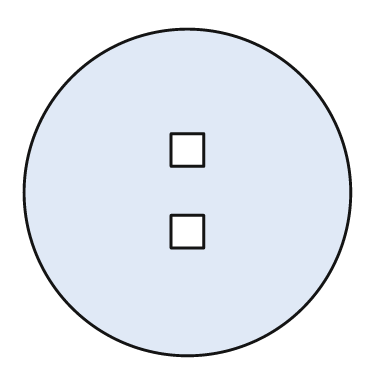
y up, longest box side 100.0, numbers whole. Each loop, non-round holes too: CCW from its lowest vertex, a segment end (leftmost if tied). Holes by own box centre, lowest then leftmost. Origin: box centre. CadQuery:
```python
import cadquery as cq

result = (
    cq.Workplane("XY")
    .moveTo(0.0, 0.0)
    .circle(50.0)
    .moveTo(-5.0, -17.0)
    .lineTo(5.0, -17.0)
    .lineTo(5.0, -7.0)
    .lineTo(-5.0, -7.0)
    .close()
    .moveTo(-5.0, 8.0)
    .lineTo(5.0, 8.0)
    .lineTo(5.0, 18.0)
    .lineTo(-5.0, 18.0)
    .close()
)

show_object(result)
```